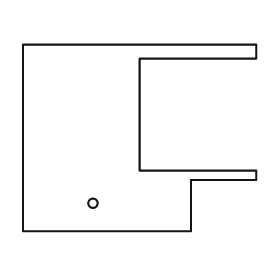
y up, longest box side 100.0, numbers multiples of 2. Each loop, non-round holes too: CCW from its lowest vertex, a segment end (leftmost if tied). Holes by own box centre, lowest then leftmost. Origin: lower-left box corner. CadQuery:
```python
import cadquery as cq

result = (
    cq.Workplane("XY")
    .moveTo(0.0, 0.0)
    .lineTo(72.0, 0.0)
    .lineTo(72.0, 22.0)
    .lineTo(100.0, 22.0)
    .lineTo(100.0, 26.0)
    .lineTo(50.0, 26.0)
    .lineTo(50.0, 74.0)
    .lineTo(100.0, 74.0)
    .lineTo(100.0, 80.0)
    .lineTo(0.0, 80.0)
    .close()
    .moveTo(30.0, 12.0)
    .circle(2.0)
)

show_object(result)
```